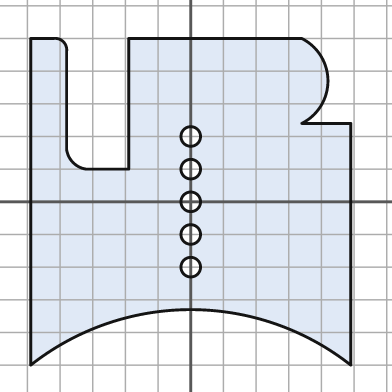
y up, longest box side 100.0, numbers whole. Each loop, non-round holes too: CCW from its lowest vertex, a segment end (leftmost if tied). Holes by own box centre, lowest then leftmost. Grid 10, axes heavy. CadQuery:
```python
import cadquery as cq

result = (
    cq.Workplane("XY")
    .moveTo(-49.0, -50.0)
    .threePointArc((0.0, -33.0), (49.0, -50.0))
    .lineTo(49.0, 24.0)
    .lineTo(34.0, 24.0)
    .threePointArc((42.0, 37.0), (34.0, 50.0))
    .lineTo(-19.0, 50.0)
    .lineTo(-19.0, 10.0)
    .lineTo(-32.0, 10.0)
    .threePointArc((-36.0, 12.0), (-38.0, 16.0))
    .lineTo(-38.0, 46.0)
    .threePointArc((-39.0, 49.0), (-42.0, 50.0))
    .lineTo(-49.0, 50.0)
    .close()
    .moveTo(0.0, -20.0)
    .circle(3.0)
    .moveTo(0.0, -10.0)
    .circle(3.0)
    .moveTo(0.0, 0.0)
    .circle(3.0)
    .moveTo(0.0, 10.0)
    .circle(3.0)
    .moveTo(0.0, 20.0)
    .circle(3.0)
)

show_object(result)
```